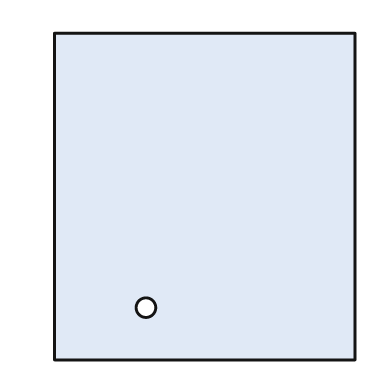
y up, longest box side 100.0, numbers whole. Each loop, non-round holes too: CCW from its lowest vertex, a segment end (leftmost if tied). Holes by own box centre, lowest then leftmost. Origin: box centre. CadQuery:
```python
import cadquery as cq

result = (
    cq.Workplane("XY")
    .moveTo(-46.0, -50.0)
    .lineTo(46.0, -50.0)
    .lineTo(46.0, 50.0)
    .lineTo(-46.0, 50.0)
    .close()
    .moveTo(-18.0, -34.0)
    .circle(3.0)
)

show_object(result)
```